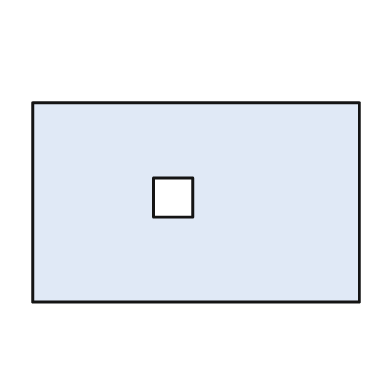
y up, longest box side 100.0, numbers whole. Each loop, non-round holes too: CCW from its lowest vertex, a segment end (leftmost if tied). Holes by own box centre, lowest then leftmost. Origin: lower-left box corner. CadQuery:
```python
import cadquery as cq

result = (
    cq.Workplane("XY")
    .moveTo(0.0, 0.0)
    .lineTo(100.0, 0.0)
    .lineTo(100.0, 61.0)
    .lineTo(0.0, 61.0)
    .close()
    .moveTo(37.0, 26.0)
    .lineTo(49.0, 26.0)
    .lineTo(49.0, 38.0)
    .lineTo(37.0, 38.0)
    .close()
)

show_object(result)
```